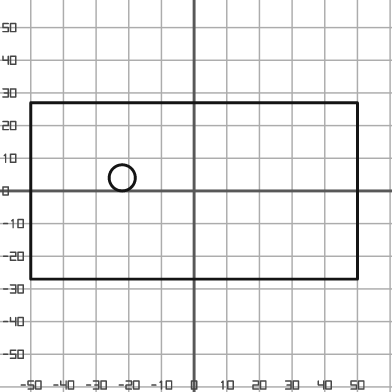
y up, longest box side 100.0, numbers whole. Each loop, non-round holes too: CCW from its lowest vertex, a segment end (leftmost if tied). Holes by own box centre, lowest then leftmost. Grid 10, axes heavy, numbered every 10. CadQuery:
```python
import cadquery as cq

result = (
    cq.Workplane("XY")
    .moveTo(-50.0, -27.0)
    .lineTo(50.0, -27.0)
    .lineTo(50.0, 27.0)
    .lineTo(-50.0, 27.0)
    .close()
    .moveTo(-22.0, 4.0)
    .circle(4.0)
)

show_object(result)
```